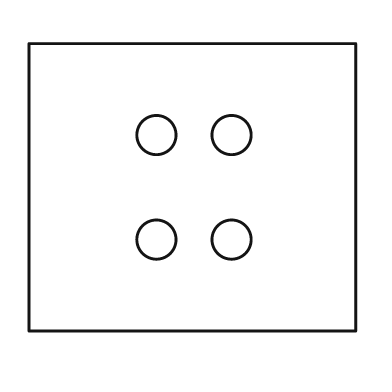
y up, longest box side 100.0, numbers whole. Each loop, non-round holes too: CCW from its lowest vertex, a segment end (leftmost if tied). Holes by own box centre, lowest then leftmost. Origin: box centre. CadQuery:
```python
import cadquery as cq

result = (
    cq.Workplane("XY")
    .moveTo(-50.0, -44.0)
    .lineTo(50.0, -44.0)
    .lineTo(50.0, 44.0)
    .lineTo(-50.0, 44.0)
    .close()
    .moveTo(-11.0, -16.0)
    .circle(6.0)
    .moveTo(12.0, -16.0)
    .circle(6.0)
    .moveTo(-11.0, 16.0)
    .circle(6.0)
    .moveTo(12.0, 16.0)
    .circle(6.0)
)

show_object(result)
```